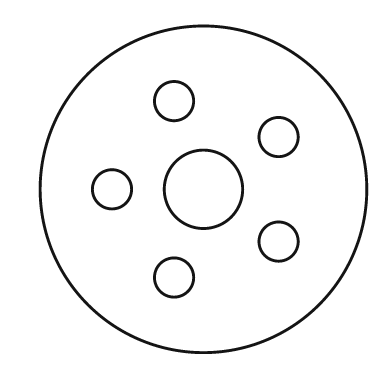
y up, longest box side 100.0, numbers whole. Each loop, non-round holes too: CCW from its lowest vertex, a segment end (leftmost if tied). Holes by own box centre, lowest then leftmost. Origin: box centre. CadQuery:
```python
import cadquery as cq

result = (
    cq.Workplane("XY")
    .moveTo(0.0, 0.0)
    .circle(50.0)
    .moveTo(-9.0, -27.0)
    .circle(6.0)
    .moveTo(23.0, -16.0)
    .circle(6.0)
    .moveTo(-28.0, 0.0)
    .circle(6.0)
    .moveTo(0.0, 0.0)
    .circle(12.0)
    .moveTo(23.0, 16.0)
    .circle(6.0)
    .moveTo(-9.0, 27.0)
    .circle(6.0)
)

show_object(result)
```